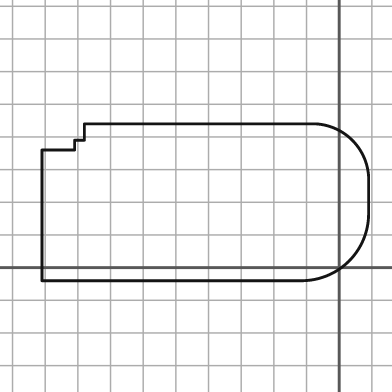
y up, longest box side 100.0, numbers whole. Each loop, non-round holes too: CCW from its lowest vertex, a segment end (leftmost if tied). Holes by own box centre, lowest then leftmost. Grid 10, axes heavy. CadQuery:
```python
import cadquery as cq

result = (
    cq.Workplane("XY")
    .moveTo(-91.0, -4.0)
    .lineTo(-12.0, -4.0)
    .threePointArc((3.0, 2.0), (9.0, 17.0))
    .lineTo(9.0, 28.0)
    .threePointArc((4.0, 39.0), (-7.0, 44.0))
    .lineTo(-78.0, 44.0)
    .lineTo(-78.0, 39.0)
    .lineTo(-81.0, 39.0)
    .lineTo(-81.0, 36.0)
    .lineTo(-91.0, 36.0)
    .close()
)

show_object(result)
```